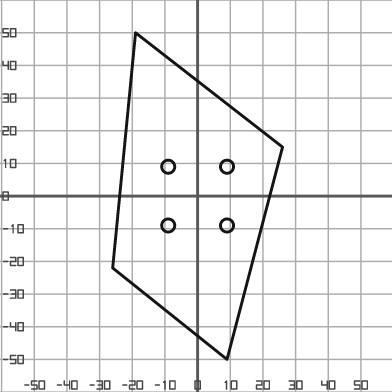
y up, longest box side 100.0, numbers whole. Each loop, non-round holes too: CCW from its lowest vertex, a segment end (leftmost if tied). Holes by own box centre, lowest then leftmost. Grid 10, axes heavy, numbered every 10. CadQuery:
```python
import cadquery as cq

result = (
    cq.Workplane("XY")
    .moveTo(9.0, -50.0)
    .lineTo(26.0, 15.0)
    .lineTo(-19.0, 50.0)
    .lineTo(-26.0, -22.0)
    .close()
    .moveTo(-9.0, -9.0)
    .circle(2.0)
    .moveTo(9.0, -9.0)
    .circle(2.0)
    .moveTo(-9.0, 9.0)
    .circle(2.0)
    .moveTo(9.0, 9.0)
    .circle(2.0)
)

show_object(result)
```